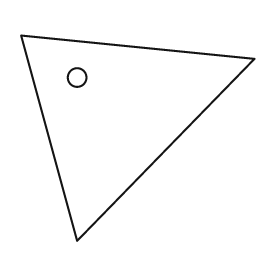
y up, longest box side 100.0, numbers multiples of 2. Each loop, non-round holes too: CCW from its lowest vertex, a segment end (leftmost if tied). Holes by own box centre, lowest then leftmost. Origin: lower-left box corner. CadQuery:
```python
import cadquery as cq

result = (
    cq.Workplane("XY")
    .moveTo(24.0, 0.0)
    .lineTo(100.0, 78.0)
    .lineTo(0.0, 88.0)
    .close()
    .moveTo(24.0, 70.0)
    .circle(4.0)
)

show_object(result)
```